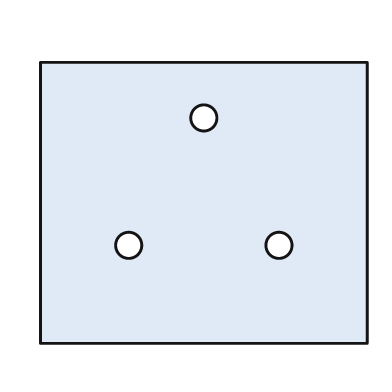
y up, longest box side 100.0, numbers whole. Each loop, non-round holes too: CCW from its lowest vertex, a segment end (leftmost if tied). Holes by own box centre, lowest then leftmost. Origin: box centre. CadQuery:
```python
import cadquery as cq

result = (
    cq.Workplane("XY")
    .moveTo(-50.0, -43.0)
    .lineTo(50.0, -43.0)
    .lineTo(50.0, 43.0)
    .lineTo(-50.0, 43.0)
    .close()
    .moveTo(-23.0, -13.0)
    .circle(4.0)
    .moveTo(23.0, -13.0)
    .circle(4.0)
    .moveTo(0.0, 26.0)
    .circle(4.0)
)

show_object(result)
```